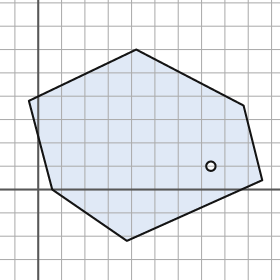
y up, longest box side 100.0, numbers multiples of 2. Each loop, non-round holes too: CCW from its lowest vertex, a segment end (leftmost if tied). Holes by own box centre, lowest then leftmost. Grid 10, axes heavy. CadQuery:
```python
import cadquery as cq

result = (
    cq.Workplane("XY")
    .moveTo(38.0, -22.0)
    .lineTo(96.0, 4.0)
    .lineTo(88.0, 36.0)
    .lineTo(42.0, 60.0)
    .lineTo(-4.0, 38.0)
    .lineTo(6.0, 0.0)
    .close()
    .moveTo(74.0, 10.0)
    .circle(2.0)
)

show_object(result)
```